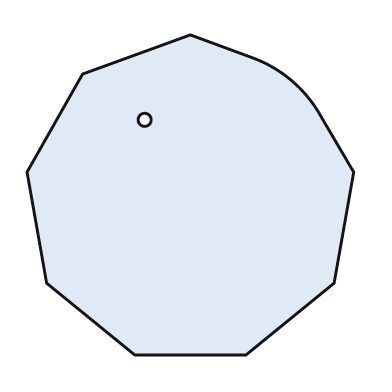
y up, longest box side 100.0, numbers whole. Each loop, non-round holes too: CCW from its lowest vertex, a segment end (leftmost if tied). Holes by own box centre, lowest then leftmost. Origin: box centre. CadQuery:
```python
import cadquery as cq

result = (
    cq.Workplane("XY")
    .moveTo(-17.0, -49.0)
    .lineTo(17.0, -49.0)
    .lineTo(44.0, -27.0)
    .lineTo(50.0, 7.0)
    .lineTo(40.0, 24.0)
    .threePointArc((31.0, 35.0), (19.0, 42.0))
    .lineTo(0.0, 49.0)
    .lineTo(-33.0, 37.0)
    .lineTo(-50.0, 7.0)
    .lineTo(-44.0, -27.0)
    .close()
    .moveTo(-14.0, 23.0)
    .circle(2.0)
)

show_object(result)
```